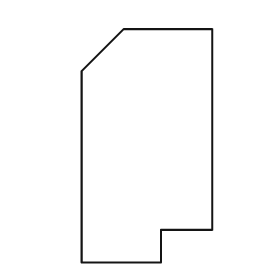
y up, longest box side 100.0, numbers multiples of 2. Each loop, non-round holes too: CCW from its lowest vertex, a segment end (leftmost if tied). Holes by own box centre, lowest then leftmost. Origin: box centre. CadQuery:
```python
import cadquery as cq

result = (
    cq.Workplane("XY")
    .moveTo(-28.0, -50.0)
    .lineTo(6.0, -50.0)
    .lineTo(6.0, -36.0)
    .lineTo(28.0, -36.0)
    .lineTo(28.0, 50.0)
    .lineTo(-10.0, 50.0)
    .lineTo(-28.0, 32.0)
    .close()
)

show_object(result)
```